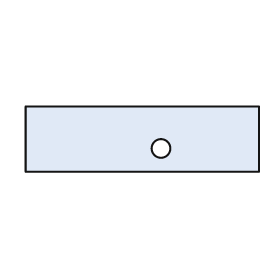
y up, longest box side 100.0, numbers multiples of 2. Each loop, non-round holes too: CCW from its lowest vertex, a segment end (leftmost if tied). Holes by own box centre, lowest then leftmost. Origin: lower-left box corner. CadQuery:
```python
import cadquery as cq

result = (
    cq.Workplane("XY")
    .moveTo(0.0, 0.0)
    .lineTo(100.0, 0.0)
    .lineTo(100.0, 28.0)
    .lineTo(0.0, 28.0)
    .close()
    .moveTo(58.0, 10.0)
    .circle(4.0)
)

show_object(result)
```